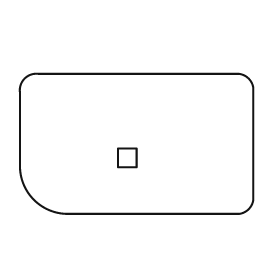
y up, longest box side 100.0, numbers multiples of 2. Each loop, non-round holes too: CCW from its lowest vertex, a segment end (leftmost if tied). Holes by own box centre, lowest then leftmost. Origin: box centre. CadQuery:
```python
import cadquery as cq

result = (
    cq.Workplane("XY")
    .moveTo(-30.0, -30.0)
    .lineTo(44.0, -30.0)
    .threePointArc((48.0, -28.0), (50.0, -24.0))
    .lineTo(50.0, 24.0)
    .threePointArc((48.0, 28.0), (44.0, 30.0))
    .lineTo(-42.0, 30.0)
    .threePointArc((-48.0, 28.0), (-50.0, 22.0))
    .lineTo(-50.0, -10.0)
    .threePointArc((-44.0, -24.0), (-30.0, -30.0))
    .close()
    .moveTo(-8.0, -10.0)
    .lineTo(0.0, -10.0)
    .lineTo(0.0, -2.0)
    .lineTo(-8.0, -2.0)
    .close()
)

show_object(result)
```